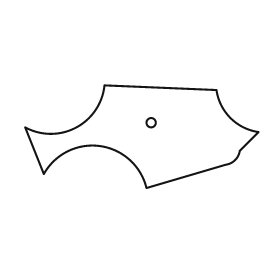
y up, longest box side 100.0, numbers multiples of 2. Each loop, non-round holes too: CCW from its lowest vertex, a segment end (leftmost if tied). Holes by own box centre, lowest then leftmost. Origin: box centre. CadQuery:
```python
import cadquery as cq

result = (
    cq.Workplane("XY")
    .moveTo(2.0, -22.0)
    .lineTo(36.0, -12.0)
    .threePointArc((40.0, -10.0), (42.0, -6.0))
    .lineTo(50.0, 2.0)
    .threePointArc((38.0, 8.0), (32.0, 20.0))
    .lineTo(-16.0, 22.0)
    .threePointArc((-28.0, 4.0), (-50.0, 4.0))
    .lineTo(-42.0, -16.0)
    .threePointArc((-18.0, -4.0), (2.0, -22.0))
    .close()
    .moveTo(4.0, 6.0)
    .circle(2.0)
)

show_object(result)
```